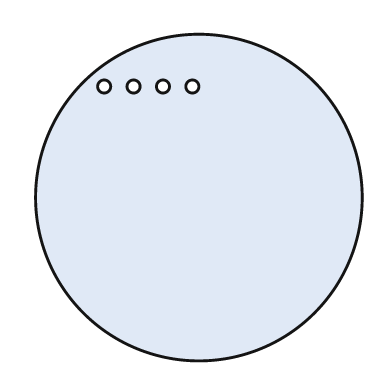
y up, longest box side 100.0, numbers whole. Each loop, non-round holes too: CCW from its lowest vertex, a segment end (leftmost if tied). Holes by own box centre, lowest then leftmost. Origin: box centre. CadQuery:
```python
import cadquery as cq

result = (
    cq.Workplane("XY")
    .moveTo(0.0, 0.0)
    .circle(50.0)
    .moveTo(-29.0, 34.0)
    .circle(2.0)
    .moveTo(-20.0, 34.0)
    .circle(2.0)
    .moveTo(-11.0, 34.0)
    .circle(2.0)
    .moveTo(-2.0, 34.0)
    .circle(2.0)
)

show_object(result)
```